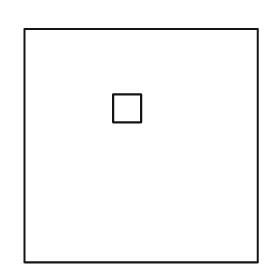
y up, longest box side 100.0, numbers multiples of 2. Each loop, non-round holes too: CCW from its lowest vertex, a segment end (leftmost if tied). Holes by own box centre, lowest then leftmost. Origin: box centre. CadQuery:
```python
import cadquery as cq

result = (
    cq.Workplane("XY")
    .moveTo(-50.0, -50.0)
    .lineTo(50.0, -50.0)
    .lineTo(50.0, 50.0)
    .lineTo(-50.0, 50.0)
    .close()
    .moveTo(-12.0, 10.0)
    .lineTo(0.0, 10.0)
    .lineTo(0.0, 22.0)
    .lineTo(-12.0, 22.0)
    .close()
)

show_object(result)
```